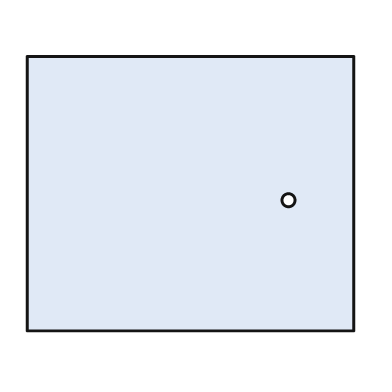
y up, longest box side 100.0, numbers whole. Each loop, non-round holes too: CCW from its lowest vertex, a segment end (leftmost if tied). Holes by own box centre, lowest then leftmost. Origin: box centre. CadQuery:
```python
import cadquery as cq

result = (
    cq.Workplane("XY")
    .moveTo(-50.0, -42.0)
    .lineTo(50.0, -42.0)
    .lineTo(50.0, 42.0)
    .lineTo(-50.0, 42.0)
    .close()
    .moveTo(30.0, -2.0)
    .circle(2.0)
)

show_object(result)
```